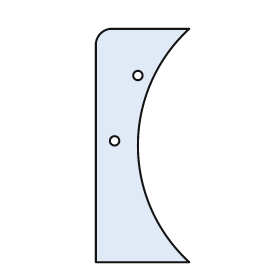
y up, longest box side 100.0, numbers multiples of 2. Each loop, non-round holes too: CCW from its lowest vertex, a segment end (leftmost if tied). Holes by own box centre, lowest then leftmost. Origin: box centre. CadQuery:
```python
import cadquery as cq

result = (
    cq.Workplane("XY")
    .moveTo(-20.0, -50.0)
    .lineTo(20.0, -50.0)
    .threePointArc((-2.0, 0.0), (20.0, 50.0))
    .lineTo(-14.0, 50.0)
    .threePointArc((-18.0, 48.0), (-20.0, 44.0))
    .close()
    .moveTo(-12.0, 2.0)
    .circle(2.0)
    .moveTo(-2.0, 30.0)
    .circle(2.0)
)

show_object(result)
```